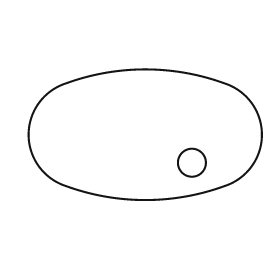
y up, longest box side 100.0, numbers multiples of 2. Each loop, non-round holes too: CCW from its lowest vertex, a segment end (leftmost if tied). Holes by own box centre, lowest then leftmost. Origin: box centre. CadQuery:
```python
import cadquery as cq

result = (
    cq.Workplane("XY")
    .moveTo(-34.0, -22.0)
    .threePointArc((0.0, -28.0), (34.0, -22.0))
    .threePointArc((50.0, 0.0), (34.0, 22.0))
    .threePointArc((0.0, 28.0), (-34.0, 22.0))
    .threePointArc((-50.0, 0.0), (-34.0, -22.0))
    .close()
    .moveTo(20.0, -12.0)
    .circle(6.0)
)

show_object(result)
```